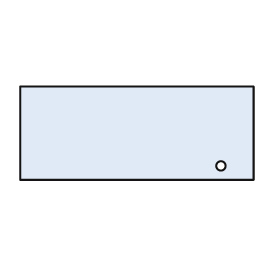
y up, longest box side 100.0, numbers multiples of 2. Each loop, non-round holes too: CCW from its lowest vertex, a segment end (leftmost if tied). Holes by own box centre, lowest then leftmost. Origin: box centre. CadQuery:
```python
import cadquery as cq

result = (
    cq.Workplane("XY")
    .moveTo(-50.0, -20.0)
    .lineTo(50.0, -20.0)
    .lineTo(50.0, 20.0)
    .lineTo(-50.0, 20.0)
    .close()
    .moveTo(36.0, -14.0)
    .circle(2.0)
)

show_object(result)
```